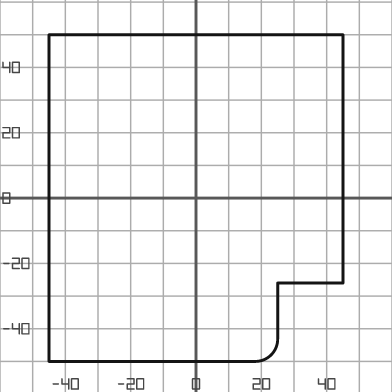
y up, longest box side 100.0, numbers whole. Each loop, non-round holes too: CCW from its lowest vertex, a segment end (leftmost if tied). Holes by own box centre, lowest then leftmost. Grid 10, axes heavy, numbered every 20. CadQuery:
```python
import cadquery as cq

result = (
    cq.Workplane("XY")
    .moveTo(-45.0, -50.0)
    .lineTo(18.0, -50.0)
    .threePointArc((23.0, -48.0), (25.0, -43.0))
    .lineTo(25.0, -26.0)
    .lineTo(45.0, -26.0)
    .lineTo(45.0, 50.0)
    .lineTo(-45.0, 50.0)
    .close()
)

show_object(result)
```